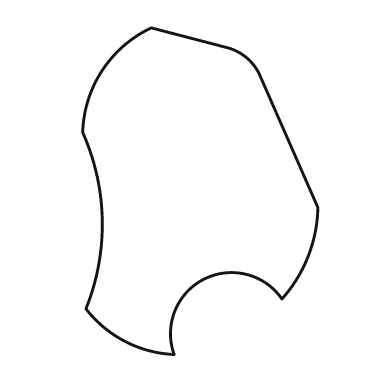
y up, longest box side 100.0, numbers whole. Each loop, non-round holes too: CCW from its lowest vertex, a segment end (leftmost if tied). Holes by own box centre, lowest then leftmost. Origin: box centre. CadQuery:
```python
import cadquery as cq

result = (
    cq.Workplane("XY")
    .moveTo(-8.0, -50.0)
    .threePointArc((1.0, -27.0), (25.0, -33.0))
    .threePointArc((33.0, -20.0), (36.0, -5.0))
    .lineTo(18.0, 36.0)
    .threePointArc((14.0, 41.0), (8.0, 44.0))
    .lineTo(-15.0, 50.0)
    .threePointArc((-30.0, 37.0), (-36.0, 18.0))
    .threePointArc((-30.0, -9.0), (-35.0, -36.0))
    .threePointArc((-23.0, -46.0), (-8.0, -50.0))
    .close()
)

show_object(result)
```